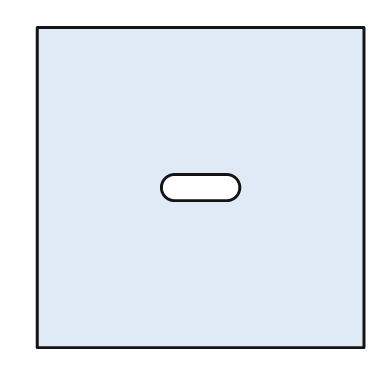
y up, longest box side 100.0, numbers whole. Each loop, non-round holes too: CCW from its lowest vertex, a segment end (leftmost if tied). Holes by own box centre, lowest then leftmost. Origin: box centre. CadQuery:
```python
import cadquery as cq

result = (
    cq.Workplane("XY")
    .moveTo(-50.0, -49.0)
    .lineTo(50.0, -49.0)
    .lineTo(50.0, 49.0)
    .lineTo(-50.0, 49.0)
    .close()
    .moveTo(-8.0, -4.0)
    .lineTo(8.0, -4.0)
    .threePointArc((12.0, 0.0), (8.0, 4.0))
    .lineTo(-8.0, 4.0)
    .threePointArc((-12.0, 0.0), (-8.0, -4.0))
    .close()
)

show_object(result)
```